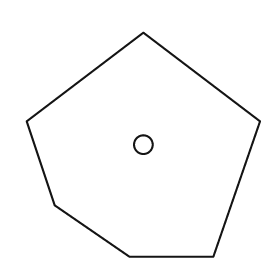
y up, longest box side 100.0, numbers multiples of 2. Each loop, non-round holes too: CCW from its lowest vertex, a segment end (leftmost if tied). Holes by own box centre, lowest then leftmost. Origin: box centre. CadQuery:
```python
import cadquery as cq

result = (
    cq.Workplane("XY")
    .moveTo(-6.0, -48.0)
    .lineTo(30.0, -48.0)
    .lineTo(50.0, 10.0)
    .lineTo(0.0, 48.0)
    .lineTo(-50.0, 10.0)
    .lineTo(-38.0, -26.0)
    .close()
    .moveTo(0.0, 0.0)
    .circle(4.0)
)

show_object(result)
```